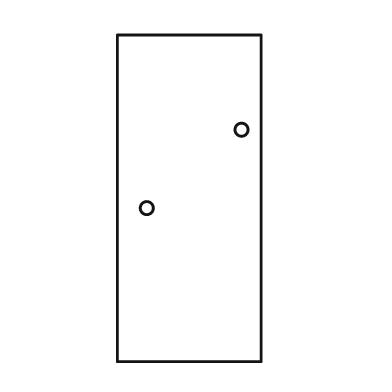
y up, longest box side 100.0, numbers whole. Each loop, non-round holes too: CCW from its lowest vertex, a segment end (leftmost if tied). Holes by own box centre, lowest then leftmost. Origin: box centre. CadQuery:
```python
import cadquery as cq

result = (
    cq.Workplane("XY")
    .moveTo(-22.0, -50.0)
    .lineTo(22.0, -50.0)
    .lineTo(22.0, 50.0)
    .lineTo(-22.0, 50.0)
    .close()
    .moveTo(-13.0, -3.0)
    .circle(2.0)
    .moveTo(16.0, 21.0)
    .circle(2.0)
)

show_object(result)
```